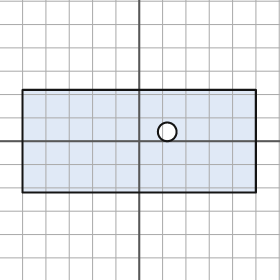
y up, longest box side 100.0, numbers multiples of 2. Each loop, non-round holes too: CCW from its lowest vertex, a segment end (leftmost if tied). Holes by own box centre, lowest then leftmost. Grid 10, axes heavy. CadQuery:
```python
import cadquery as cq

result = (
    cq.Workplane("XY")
    .moveTo(-50.0, -22.0)
    .lineTo(50.0, -22.0)
    .lineTo(50.0, 22.0)
    .lineTo(-50.0, 22.0)
    .close()
    .moveTo(12.0, 4.0)
    .circle(4.0)
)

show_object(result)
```